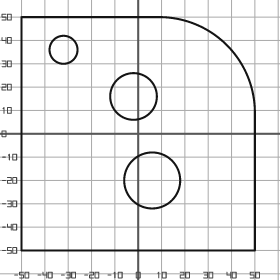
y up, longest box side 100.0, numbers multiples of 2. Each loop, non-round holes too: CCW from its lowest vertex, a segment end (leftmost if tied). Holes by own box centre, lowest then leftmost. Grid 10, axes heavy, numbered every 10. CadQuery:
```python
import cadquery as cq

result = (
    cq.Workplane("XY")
    .moveTo(-50.0, -50.0)
    .lineTo(50.0, -50.0)
    .lineTo(50.0, 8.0)
    .threePointArc((38.0, 38.0), (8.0, 50.0))
    .lineTo(-50.0, 50.0)
    .close()
    .moveTo(6.0, -20.0)
    .circle(12.0)
    .moveTo(-2.0, 16.0)
    .circle(10.0)
    .moveTo(-32.0, 36.0)
    .circle(6.0)
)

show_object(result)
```